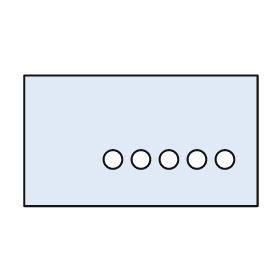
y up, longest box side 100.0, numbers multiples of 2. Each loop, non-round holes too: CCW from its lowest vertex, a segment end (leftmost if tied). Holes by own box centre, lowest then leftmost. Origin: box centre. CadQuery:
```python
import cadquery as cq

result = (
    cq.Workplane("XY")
    .moveTo(-50.0, -28.0)
    .lineTo(50.0, -28.0)
    .lineTo(50.0, 28.0)
    .lineTo(-50.0, 28.0)
    .close()
    .moveTo(-12.0, -8.0)
    .circle(4.0)
    .moveTo(0.0, -8.0)
    .circle(4.0)
    .moveTo(12.0, -8.0)
    .circle(4.0)
    .moveTo(24.0, -8.0)
    .circle(4.0)
    .moveTo(36.0, -8.0)
    .circle(4.0)
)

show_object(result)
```